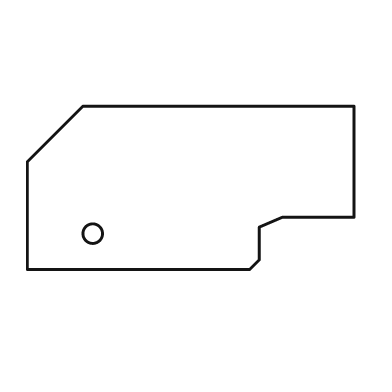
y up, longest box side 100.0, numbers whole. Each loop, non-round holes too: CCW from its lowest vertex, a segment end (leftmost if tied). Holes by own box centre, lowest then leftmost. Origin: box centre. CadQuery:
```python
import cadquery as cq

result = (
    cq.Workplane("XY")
    .moveTo(-50.0, -25.0)
    .lineTo(18.0, -25.0)
    .lineTo(21.0, -22.0)
    .lineTo(21.0, -12.0)
    .lineTo(28.0, -9.0)
    .lineTo(50.0, -9.0)
    .lineTo(50.0, 25.0)
    .lineTo(-33.0, 25.0)
    .lineTo(-50.0, 8.0)
    .close()
    .moveTo(-30.0, -14.0)
    .circle(3.0)
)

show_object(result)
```